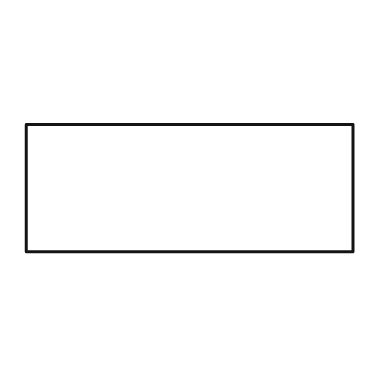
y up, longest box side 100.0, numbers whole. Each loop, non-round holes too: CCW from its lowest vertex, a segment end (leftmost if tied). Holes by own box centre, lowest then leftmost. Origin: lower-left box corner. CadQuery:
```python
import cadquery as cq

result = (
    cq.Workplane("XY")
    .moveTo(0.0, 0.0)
    .lineTo(100.0, 0.0)
    .lineTo(100.0, 39.0)
    .lineTo(0.0, 39.0)
    .close()
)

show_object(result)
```